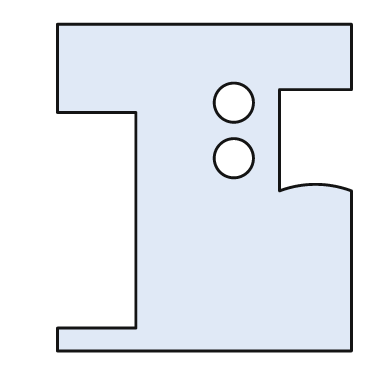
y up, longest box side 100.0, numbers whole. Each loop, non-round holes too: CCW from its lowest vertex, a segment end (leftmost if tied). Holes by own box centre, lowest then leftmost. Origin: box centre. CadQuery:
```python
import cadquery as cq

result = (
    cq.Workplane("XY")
    .moveTo(-45.0, -50.0)
    .lineTo(45.0, -50.0)
    .lineTo(45.0, -1.0)
    .threePointArc((34.0, 1.0), (23.0, -1.0))
    .lineTo(23.0, 30.0)
    .lineTo(45.0, 30.0)
    .lineTo(45.0, 50.0)
    .lineTo(-45.0, 50.0)
    .lineTo(-45.0, 23.0)
    .lineTo(-21.0, 23.0)
    .lineTo(-21.0, -43.0)
    .lineTo(-45.0, -43.0)
    .close()
    .moveTo(9.0, 9.0)
    .circle(6.0)
    .moveTo(9.0, 26.0)
    .circle(6.0)
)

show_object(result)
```